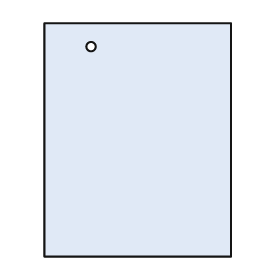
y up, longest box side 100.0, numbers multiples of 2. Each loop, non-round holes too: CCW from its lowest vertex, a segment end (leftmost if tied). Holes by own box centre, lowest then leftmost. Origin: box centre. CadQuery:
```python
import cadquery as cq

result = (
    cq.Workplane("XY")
    .moveTo(-40.0, -50.0)
    .lineTo(40.0, -50.0)
    .lineTo(40.0, 50.0)
    .lineTo(-40.0, 50.0)
    .close()
    .moveTo(-20.0, 40.0)
    .circle(2.0)
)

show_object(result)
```